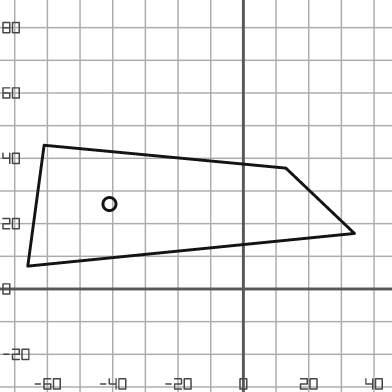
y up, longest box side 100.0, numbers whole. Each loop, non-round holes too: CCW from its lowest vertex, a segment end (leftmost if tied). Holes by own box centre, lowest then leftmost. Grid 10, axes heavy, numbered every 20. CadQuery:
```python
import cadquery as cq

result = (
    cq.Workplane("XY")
    .moveTo(-66.0, 7.0)
    .lineTo(34.0, 17.0)
    .lineTo(13.0, 37.0)
    .lineTo(-61.0, 44.0)
    .close()
    .moveTo(-41.0, 26.0)
    .circle(2.0)
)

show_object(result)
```